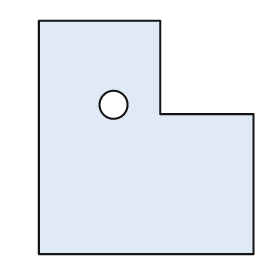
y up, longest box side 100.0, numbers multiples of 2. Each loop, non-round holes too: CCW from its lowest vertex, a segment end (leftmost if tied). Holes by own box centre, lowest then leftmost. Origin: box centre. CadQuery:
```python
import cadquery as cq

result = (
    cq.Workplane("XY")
    .moveTo(-46.0, -50.0)
    .lineTo(46.0, -50.0)
    .lineTo(46.0, 10.0)
    .lineTo(6.0, 10.0)
    .lineTo(6.0, 50.0)
    .lineTo(-46.0, 50.0)
    .close()
    .moveTo(-14.0, 14.0)
    .circle(6.0)
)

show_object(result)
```